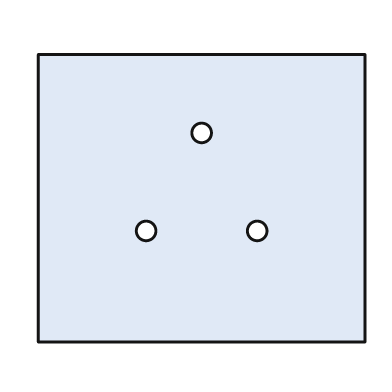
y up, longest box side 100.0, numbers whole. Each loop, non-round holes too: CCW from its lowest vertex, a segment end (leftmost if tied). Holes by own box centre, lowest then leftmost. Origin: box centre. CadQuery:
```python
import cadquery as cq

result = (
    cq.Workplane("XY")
    .moveTo(-50.0, -44.0)
    .lineTo(50.0, -44.0)
    .lineTo(50.0, 44.0)
    .lineTo(-50.0, 44.0)
    .close()
    .moveTo(-17.0, -10.0)
    .circle(3.0)
    .moveTo(17.0, -10.0)
    .circle(3.0)
    .moveTo(0.0, 20.0)
    .circle(3.0)
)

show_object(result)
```